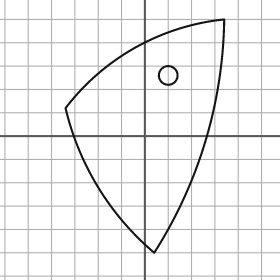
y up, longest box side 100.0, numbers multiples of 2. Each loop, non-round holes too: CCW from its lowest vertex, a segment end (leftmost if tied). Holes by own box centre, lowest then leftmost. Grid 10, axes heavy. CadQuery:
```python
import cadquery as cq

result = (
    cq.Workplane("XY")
    .moveTo(4.0, -50.0)
    .threePointArc((26.0, -2.0), (34.0, 50.0))
    .threePointArc((-4.0, 38.0), (-34.0, 12.0))
    .threePointArc((-20.0, -22.0), (4.0, -50.0))
    .close()
    .moveTo(10.0, 26.0)
    .circle(4.0)
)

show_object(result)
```